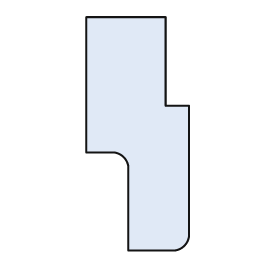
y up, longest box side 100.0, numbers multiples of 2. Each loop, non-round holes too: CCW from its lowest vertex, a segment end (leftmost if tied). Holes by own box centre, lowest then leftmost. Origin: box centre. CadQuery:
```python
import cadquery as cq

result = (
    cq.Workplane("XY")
    .moveTo(-4.0, -50.0)
    .lineTo(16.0, -50.0)
    .threePointArc((20.0, -48.0), (22.0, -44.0))
    .lineTo(22.0, 12.0)
    .lineTo(12.0, 12.0)
    .lineTo(12.0, 50.0)
    .lineTo(-22.0, 50.0)
    .lineTo(-22.0, -8.0)
    .lineTo(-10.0, -8.0)
    .threePointArc((-6.0, -10.0), (-4.0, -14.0))
    .close()
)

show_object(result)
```